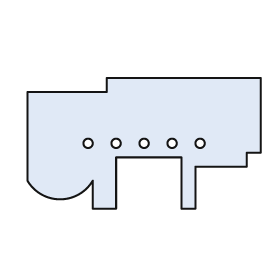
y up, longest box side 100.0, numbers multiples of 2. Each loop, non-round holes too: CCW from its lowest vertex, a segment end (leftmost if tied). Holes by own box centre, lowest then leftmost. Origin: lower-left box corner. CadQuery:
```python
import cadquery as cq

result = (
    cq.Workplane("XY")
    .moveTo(28.0, 0.0)
    .lineTo(38.0, 0.0)
    .lineTo(38.0, 22.0)
    .lineTo(66.0, 22.0)
    .lineTo(66.0, 0.0)
    .lineTo(72.0, 0.0)
    .lineTo(72.0, 18.0)
    .lineTo(94.0, 18.0)
    .lineTo(94.0, 24.0)
    .lineTo(100.0, 24.0)
    .lineTo(100.0, 56.0)
    .lineTo(34.0, 56.0)
    .lineTo(34.0, 50.0)
    .lineTo(0.0, 50.0)
    .lineTo(0.0, 12.0)
    .threePointArc((14.0, 4.0), (28.0, 12.0))
    .close()
    .moveTo(26.0, 28.0)
    .circle(2.0)
    .moveTo(38.0, 28.0)
    .circle(2.0)
    .moveTo(50.0, 28.0)
    .circle(2.0)
    .moveTo(62.0, 28.0)
    .circle(2.0)
    .moveTo(74.0, 28.0)
    .circle(2.0)
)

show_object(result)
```